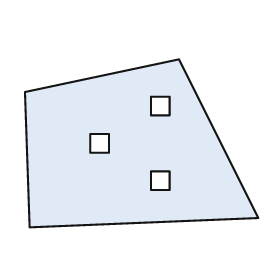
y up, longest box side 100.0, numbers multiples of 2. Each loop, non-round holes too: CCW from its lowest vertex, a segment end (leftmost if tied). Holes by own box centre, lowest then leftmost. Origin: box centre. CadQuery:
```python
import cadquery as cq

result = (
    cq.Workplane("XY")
    .moveTo(-48.0, -36.0)
    .lineTo(50.0, -32.0)
    .lineTo(16.0, 36.0)
    .lineTo(-50.0, 22.0)
    .close()
    .moveTo(4.0, -20.0)
    .lineTo(12.0, -20.0)
    .lineTo(12.0, -12.0)
    .lineTo(4.0, -12.0)
    .close()
    .moveTo(-22.0, -4.0)
    .lineTo(-14.0, -4.0)
    .lineTo(-14.0, 4.0)
    .lineTo(-22.0, 4.0)
    .close()
    .moveTo(4.0, 12.0)
    .lineTo(12.0, 12.0)
    .lineTo(12.0, 20.0)
    .lineTo(4.0, 20.0)
    .close()
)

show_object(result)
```